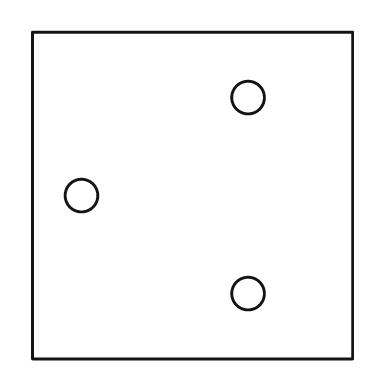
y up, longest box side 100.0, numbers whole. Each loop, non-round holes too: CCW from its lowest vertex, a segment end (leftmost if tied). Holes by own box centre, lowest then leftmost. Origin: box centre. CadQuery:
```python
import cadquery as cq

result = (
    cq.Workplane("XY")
    .moveTo(-49.0, -50.0)
    .lineTo(49.0, -50.0)
    .lineTo(49.0, 50.0)
    .lineTo(-49.0, 50.0)
    .close()
    .moveTo(17.0, -30.0)
    .circle(5.0)
    .moveTo(-34.0, 0.0)
    .circle(5.0)
    .moveTo(17.0, 30.0)
    .circle(5.0)
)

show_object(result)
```